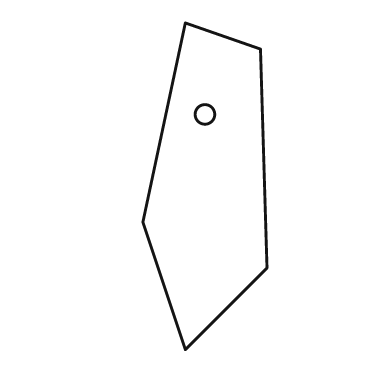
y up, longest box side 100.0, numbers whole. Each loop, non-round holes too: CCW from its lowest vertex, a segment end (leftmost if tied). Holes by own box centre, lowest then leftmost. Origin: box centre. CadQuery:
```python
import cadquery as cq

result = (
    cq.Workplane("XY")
    .moveTo(-6.0, -50.0)
    .lineTo(19.0, -25.0)
    .lineTo(17.0, 42.0)
    .lineTo(-6.0, 50.0)
    .lineTo(-19.0, -11.0)
    .close()
    .moveTo(0.0, 22.0)
    .circle(3.0)
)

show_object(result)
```